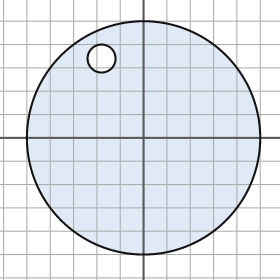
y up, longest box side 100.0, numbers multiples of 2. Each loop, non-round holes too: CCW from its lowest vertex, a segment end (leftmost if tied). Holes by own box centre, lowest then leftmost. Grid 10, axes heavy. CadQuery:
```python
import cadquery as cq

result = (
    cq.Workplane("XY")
    .moveTo(0.0, 0.0)
    .circle(50.0)
    .moveTo(-18.0, 34.0)
    .circle(6.0)
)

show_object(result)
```